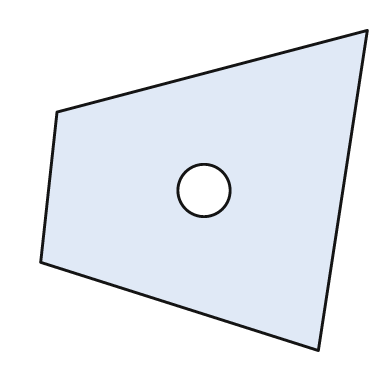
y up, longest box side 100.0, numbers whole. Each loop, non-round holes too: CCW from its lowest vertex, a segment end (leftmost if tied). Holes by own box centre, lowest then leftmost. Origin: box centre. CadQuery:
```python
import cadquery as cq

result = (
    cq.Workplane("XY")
    .moveTo(35.0, -49.0)
    .lineTo(50.0, 49.0)
    .lineTo(-45.0, 24.0)
    .lineTo(-50.0, -22.0)
    .close()
    .moveTo(0.0, 0.0)
    .circle(8.0)
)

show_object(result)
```